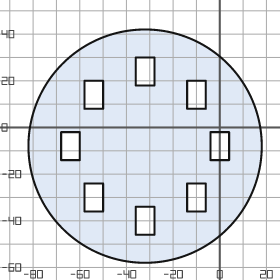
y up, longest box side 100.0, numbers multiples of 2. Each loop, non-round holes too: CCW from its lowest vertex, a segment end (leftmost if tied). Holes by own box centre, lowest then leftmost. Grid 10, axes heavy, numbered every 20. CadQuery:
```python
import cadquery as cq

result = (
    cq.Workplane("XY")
    .moveTo(-32.0, -8.0)
    .circle(50.0)
    .moveTo(-36.0, -46.0)
    .lineTo(-28.0, -46.0)
    .lineTo(-28.0, -34.0)
    .lineTo(-36.0, -34.0)
    .close()
    .moveTo(-58.0, -36.0)
    .lineTo(-50.0, -36.0)
    .lineTo(-50.0, -24.0)
    .lineTo(-58.0, -24.0)
    .close()
    .moveTo(-14.0, -36.0)
    .lineTo(-6.0, -36.0)
    .lineTo(-6.0, -24.0)
    .lineTo(-14.0, -24.0)
    .close()
    .moveTo(-68.0, -14.0)
    .lineTo(-60.0, -14.0)
    .lineTo(-60.0, -2.0)
    .lineTo(-68.0, -2.0)
    .close()
    .moveTo(-4.0, -14.0)
    .lineTo(4.0, -14.0)
    .lineTo(4.0, -2.0)
    .lineTo(-4.0, -2.0)
    .close()
    .moveTo(-58.0, 8.0)
    .lineTo(-50.0, 8.0)
    .lineTo(-50.0, 20.0)
    .lineTo(-58.0, 20.0)
    .close()
    .moveTo(-14.0, 8.0)
    .lineTo(-6.0, 8.0)
    .lineTo(-6.0, 20.0)
    .lineTo(-14.0, 20.0)
    .close()
    .moveTo(-36.0, 18.0)
    .lineTo(-28.0, 18.0)
    .lineTo(-28.0, 30.0)
    .lineTo(-36.0, 30.0)
    .close()
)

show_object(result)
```